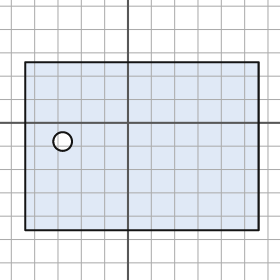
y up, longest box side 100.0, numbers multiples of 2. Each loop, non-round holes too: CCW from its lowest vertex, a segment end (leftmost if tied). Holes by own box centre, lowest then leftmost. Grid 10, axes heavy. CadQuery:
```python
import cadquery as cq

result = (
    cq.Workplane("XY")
    .moveTo(-44.0, -46.0)
    .lineTo(56.0, -46.0)
    .lineTo(56.0, 26.0)
    .lineTo(-44.0, 26.0)
    .close()
    .moveTo(-28.0, -8.0)
    .circle(4.0)
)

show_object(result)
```